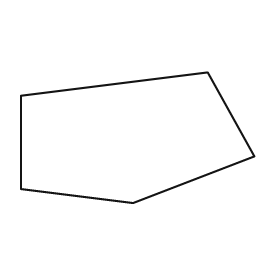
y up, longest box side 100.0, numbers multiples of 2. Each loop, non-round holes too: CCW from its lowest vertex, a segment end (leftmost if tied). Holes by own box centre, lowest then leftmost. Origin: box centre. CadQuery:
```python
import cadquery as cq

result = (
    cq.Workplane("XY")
    .moveTo(-2.0, -28.0)
    .lineTo(50.0, -8.0)
    .lineTo(30.0, 28.0)
    .lineTo(-50.0, 18.0)
    .lineTo(-50.0, -22.0)
    .close()
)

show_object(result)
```